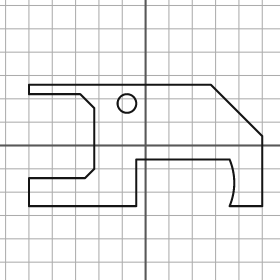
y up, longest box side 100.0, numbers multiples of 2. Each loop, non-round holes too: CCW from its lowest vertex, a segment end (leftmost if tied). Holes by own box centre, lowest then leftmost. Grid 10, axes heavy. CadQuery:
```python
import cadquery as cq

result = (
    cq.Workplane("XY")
    .moveTo(-50.0, -26.0)
    .lineTo(-4.0, -26.0)
    .lineTo(-4.0, -6.0)
    .lineTo(36.0, -6.0)
    .threePointArc((38.0, -16.0), (36.0, -26.0))
    .lineTo(50.0, -26.0)
    .lineTo(50.0, 4.0)
    .lineTo(28.0, 26.0)
    .lineTo(-50.0, 26.0)
    .lineTo(-50.0, 22.0)
    .lineTo(-28.0, 22.0)
    .lineTo(-22.0, 16.0)
    .lineTo(-22.0, -10.0)
    .lineTo(-26.0, -14.0)
    .lineTo(-50.0, -14.0)
    .close()
    .moveTo(-8.0, 18.0)
    .circle(4.0)
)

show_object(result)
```